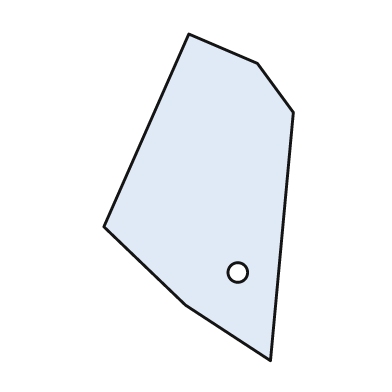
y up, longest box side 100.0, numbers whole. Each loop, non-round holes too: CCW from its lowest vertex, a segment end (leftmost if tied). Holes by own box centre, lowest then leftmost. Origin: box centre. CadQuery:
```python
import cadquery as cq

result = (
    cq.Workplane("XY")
    .moveTo(22.0, -50.0)
    .lineTo(29.0, 26.0)
    .lineTo(18.0, 41.0)
    .lineTo(-3.0, 50.0)
    .lineTo(-29.0, -9.0)
    .lineTo(-4.0, -33.0)
    .close()
    .moveTo(12.0, -23.0)
    .circle(3.0)
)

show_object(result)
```